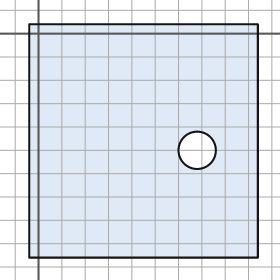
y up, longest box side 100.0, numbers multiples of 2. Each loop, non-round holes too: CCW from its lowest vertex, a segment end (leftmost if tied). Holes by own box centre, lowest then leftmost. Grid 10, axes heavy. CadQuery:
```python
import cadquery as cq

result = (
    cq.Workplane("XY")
    .moveTo(-4.0, -96.0)
    .lineTo(94.0, -96.0)
    .lineTo(94.0, 4.0)
    .lineTo(-4.0, 4.0)
    .close()
    .moveTo(68.0, -50.0)
    .circle(8.0)
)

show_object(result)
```